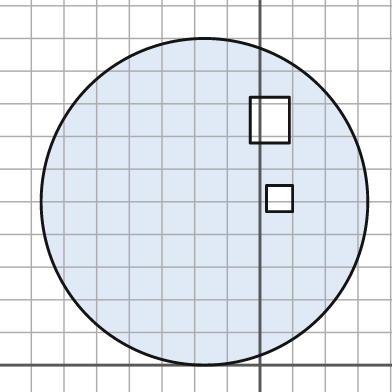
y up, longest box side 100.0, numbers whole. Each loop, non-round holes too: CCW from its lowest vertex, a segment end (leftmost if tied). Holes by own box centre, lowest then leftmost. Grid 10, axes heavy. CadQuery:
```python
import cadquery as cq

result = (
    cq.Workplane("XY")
    .moveTo(-17.0, 50.0)
    .circle(50.0)
    .moveTo(2.0, 47.0)
    .lineTo(10.0, 47.0)
    .lineTo(10.0, 55.0)
    .lineTo(2.0, 55.0)
    .close()
    .moveTo(-3.0, 68.0)
    .lineTo(9.0, 68.0)
    .lineTo(9.0, 82.0)
    .lineTo(-3.0, 82.0)
    .close()
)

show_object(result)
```